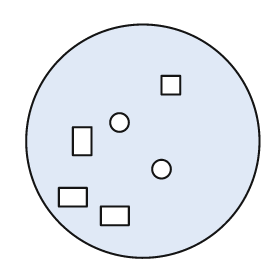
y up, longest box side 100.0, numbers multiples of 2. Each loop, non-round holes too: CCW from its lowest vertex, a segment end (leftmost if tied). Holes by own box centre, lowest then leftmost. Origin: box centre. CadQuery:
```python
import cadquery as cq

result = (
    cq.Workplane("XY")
    .moveTo(0.0, 0.0)
    .circle(50.0)
    .moveTo(-18.0, -36.0)
    .lineTo(-6.0, -36.0)
    .lineTo(-6.0, -28.0)
    .lineTo(-18.0, -28.0)
    .close()
    .moveTo(-36.0, -28.0)
    .lineTo(-24.0, -28.0)
    .lineTo(-24.0, -20.0)
    .lineTo(-36.0, -20.0)
    .close()
    .moveTo(8.0, -12.0)
    .circle(4.0)
    .moveTo(-30.0, -6.0)
    .lineTo(-22.0, -6.0)
    .lineTo(-22.0, 6.0)
    .lineTo(-30.0, 6.0)
    .close()
    .moveTo(-10.0, 8.0)
    .circle(4.0)
    .moveTo(8.0, 20.0)
    .lineTo(16.0, 20.0)
    .lineTo(16.0, 28.0)
    .lineTo(8.0, 28.0)
    .close()
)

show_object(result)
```